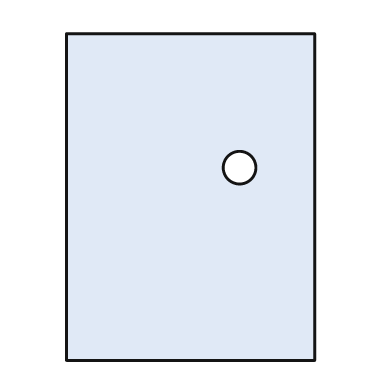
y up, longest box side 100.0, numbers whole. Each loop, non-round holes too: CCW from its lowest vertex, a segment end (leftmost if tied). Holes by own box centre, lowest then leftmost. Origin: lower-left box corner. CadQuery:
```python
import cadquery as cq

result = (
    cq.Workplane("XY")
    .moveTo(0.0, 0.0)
    .lineTo(76.0, 0.0)
    .lineTo(76.0, 100.0)
    .lineTo(0.0, 100.0)
    .close()
    .moveTo(53.0, 59.0)
    .circle(5.0)
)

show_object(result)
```